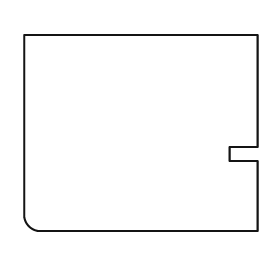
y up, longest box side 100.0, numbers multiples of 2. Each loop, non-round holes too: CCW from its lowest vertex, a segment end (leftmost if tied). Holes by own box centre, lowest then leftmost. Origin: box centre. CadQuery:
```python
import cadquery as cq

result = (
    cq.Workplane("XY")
    .moveTo(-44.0, -42.0)
    .lineTo(50.0, -42.0)
    .lineTo(50.0, -12.0)
    .lineTo(38.0, -12.0)
    .lineTo(38.0, -6.0)
    .lineTo(50.0, -6.0)
    .lineTo(50.0, 42.0)
    .lineTo(-50.0, 42.0)
    .lineTo(-50.0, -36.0)
    .threePointArc((-48.0, -40.0), (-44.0, -42.0))
    .close()
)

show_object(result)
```